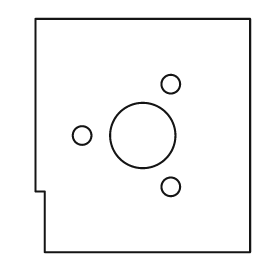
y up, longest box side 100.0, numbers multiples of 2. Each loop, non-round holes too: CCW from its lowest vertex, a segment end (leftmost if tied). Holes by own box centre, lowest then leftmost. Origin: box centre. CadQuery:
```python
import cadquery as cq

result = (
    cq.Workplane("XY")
    .moveTo(-42.0, -50.0)
    .lineTo(46.0, -50.0)
    .lineTo(46.0, 50.0)
    .lineTo(-46.0, 50.0)
    .lineTo(-46.0, -24.0)
    .lineTo(-42.0, -24.0)
    .close()
    .moveTo(12.0, -22.0)
    .circle(4.0)
    .moveTo(-26.0, 0.0)
    .circle(4.0)
    .moveTo(0.0, 0.0)
    .circle(14.0)
    .moveTo(12.0, 22.0)
    .circle(4.0)
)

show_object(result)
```